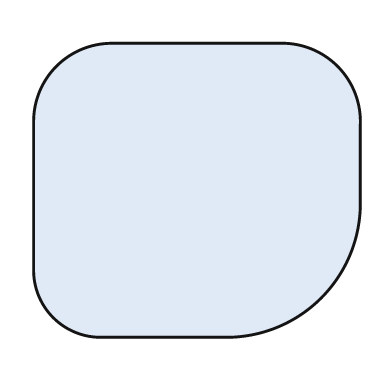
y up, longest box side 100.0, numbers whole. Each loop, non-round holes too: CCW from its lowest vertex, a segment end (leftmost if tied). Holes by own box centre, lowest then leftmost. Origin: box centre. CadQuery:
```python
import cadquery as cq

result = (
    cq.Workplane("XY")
    .moveTo(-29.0, -45.0)
    .lineTo(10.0, -45.0)
    .threePointArc((38.0, -33.0), (50.0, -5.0))
    .lineTo(50.0, 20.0)
    .threePointArc((43.0, 38.0), (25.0, 45.0))
    .lineTo(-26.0, 45.0)
    .threePointArc((-43.0, 38.0), (-50.0, 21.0))
    .lineTo(-50.0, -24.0)
    .threePointArc((-44.0, -39.0), (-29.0, -45.0))
    .close()
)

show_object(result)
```